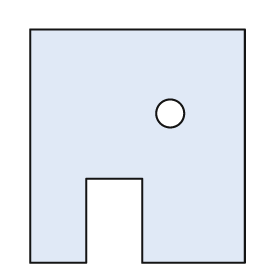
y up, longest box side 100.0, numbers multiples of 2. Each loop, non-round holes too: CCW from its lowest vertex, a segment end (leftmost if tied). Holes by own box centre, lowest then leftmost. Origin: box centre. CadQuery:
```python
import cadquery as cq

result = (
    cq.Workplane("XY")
    .moveTo(-46.0, -50.0)
    .lineTo(-22.0, -50.0)
    .lineTo(-22.0, -14.0)
    .lineTo(2.0, -14.0)
    .lineTo(2.0, -50.0)
    .lineTo(46.0, -50.0)
    .lineTo(46.0, 50.0)
    .lineTo(-46.0, 50.0)
    .close()
    .moveTo(14.0, 14.0)
    .circle(6.0)
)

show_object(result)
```